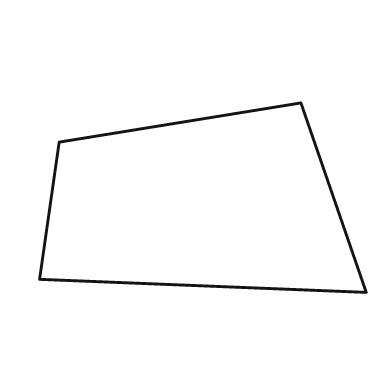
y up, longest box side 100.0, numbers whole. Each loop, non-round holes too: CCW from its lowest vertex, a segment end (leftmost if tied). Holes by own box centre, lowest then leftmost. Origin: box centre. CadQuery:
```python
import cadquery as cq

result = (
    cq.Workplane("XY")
    .moveTo(50.0, -29.0)
    .lineTo(30.0, 29.0)
    .lineTo(-44.0, 17.0)
    .lineTo(-50.0, -25.0)
    .close()
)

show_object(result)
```